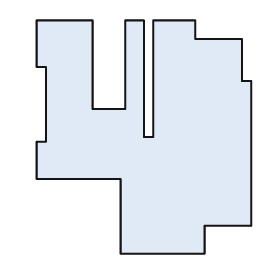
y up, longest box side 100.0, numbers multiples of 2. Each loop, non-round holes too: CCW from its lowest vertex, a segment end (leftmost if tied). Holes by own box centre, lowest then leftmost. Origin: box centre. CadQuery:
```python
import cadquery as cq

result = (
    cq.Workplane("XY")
    .moveTo(-10.0, -50.0)
    .lineTo(26.0, -50.0)
    .lineTo(26.0, -38.0)
    .lineTo(46.0, -38.0)
    .lineTo(46.0, 24.0)
    .lineTo(42.0, 24.0)
    .lineTo(42.0, 42.0)
    .lineTo(22.0, 42.0)
    .lineTo(22.0, 50.0)
    .lineTo(4.0, 50.0)
    .lineTo(4.0, 0.0)
    .lineTo(0.0, 0.0)
    .lineTo(0.0, 50.0)
    .lineTo(-8.0, 50.0)
    .lineTo(-8.0, 12.0)
    .lineTo(-22.0, 12.0)
    .lineTo(-22.0, 50.0)
    .lineTo(-46.0, 50.0)
    .lineTo(-46.0, 30.0)
    .lineTo(-42.0, 30.0)
    .lineTo(-42.0, -2.0)
    .lineTo(-46.0, -2.0)
    .lineTo(-46.0, -18.0)
    .lineTo(-10.0, -18.0)
    .close()
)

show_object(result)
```